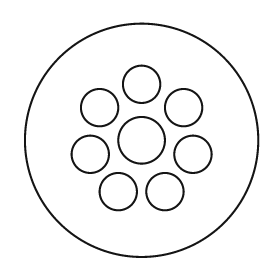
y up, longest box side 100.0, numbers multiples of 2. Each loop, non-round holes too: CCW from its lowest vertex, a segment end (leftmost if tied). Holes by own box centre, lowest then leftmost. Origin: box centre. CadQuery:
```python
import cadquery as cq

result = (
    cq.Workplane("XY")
    .moveTo(0.0, 0.0)
    .circle(50.0)
    .moveTo(-10.0, -22.0)
    .circle(8.0)
    .moveTo(10.0, -22.0)
    .circle(8.0)
    .moveTo(-22.0, -6.0)
    .circle(8.0)
    .moveTo(22.0, -6.0)
    .circle(8.0)
    .moveTo(0.0, 0.0)
    .circle(10.0)
    .moveTo(-18.0, 14.0)
    .circle(8.0)
    .moveTo(18.0, 14.0)
    .circle(8.0)
    .moveTo(0.0, 24.0)
    .circle(8.0)
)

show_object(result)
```